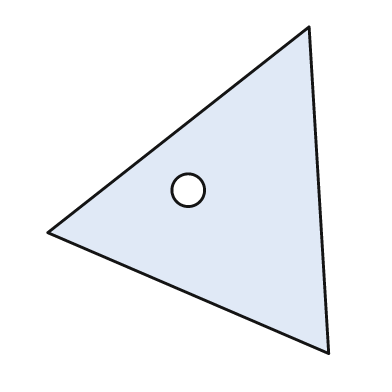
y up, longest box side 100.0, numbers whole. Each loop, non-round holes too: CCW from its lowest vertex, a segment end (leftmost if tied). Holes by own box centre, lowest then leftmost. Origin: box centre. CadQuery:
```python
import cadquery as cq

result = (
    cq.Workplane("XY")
    .moveTo(43.0, -50.0)
    .lineTo(37.0, 50.0)
    .lineTo(-43.0, -13.0)
    .close()
    .moveTo(0.0, 0.0)
    .circle(5.0)
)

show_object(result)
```